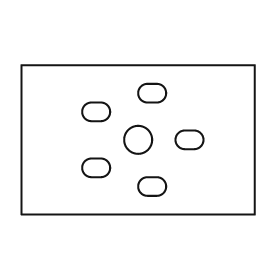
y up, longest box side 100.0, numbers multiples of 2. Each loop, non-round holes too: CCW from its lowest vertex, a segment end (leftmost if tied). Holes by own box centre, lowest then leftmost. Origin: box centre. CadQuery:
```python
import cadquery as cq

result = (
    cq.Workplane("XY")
    .moveTo(-50.0, -32.0)
    .lineTo(50.0, -32.0)
    .lineTo(50.0, 32.0)
    .lineTo(-50.0, 32.0)
    .close()
    .moveTo(4.0, -24.0)
    .lineTo(8.0, -24.0)
    .threePointArc((12.0, -20.0), (8.0, -16.0))
    .lineTo(4.0, -16.0)
    .threePointArc((0.0, -20.0), (4.0, -24.0))
    .close()
    .moveTo(-20.0, -16.0)
    .lineTo(-16.0, -16.0)
    .threePointArc((-12.0, -12.0), (-16.0, -8.0))
    .lineTo(-20.0, -8.0)
    .threePointArc((-24.0, -12.0), (-20.0, -16.0))
    .close()
    .moveTo(0.0, 0.0)
    .circle(6.0)
    .moveTo(20.0, -4.0)
    .lineTo(24.0, -4.0)
    .threePointArc((28.0, 0.0), (24.0, 4.0))
    .lineTo(20.0, 4.0)
    .threePointArc((16.0, 0.0), (20.0, -4.0))
    .close()
    .moveTo(-20.0, 8.0)
    .lineTo(-16.0, 8.0)
    .threePointArc((-12.0, 12.0), (-16.0, 16.0))
    .lineTo(-20.0, 16.0)
    .threePointArc((-24.0, 12.0), (-20.0, 8.0))
    .close()
    .moveTo(4.0, 16.0)
    .lineTo(8.0, 16.0)
    .threePointArc((12.0, 20.0), (8.0, 24.0))
    .lineTo(4.0, 24.0)
    .threePointArc((0.0, 20.0), (4.0, 16.0))
    .close()
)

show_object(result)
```